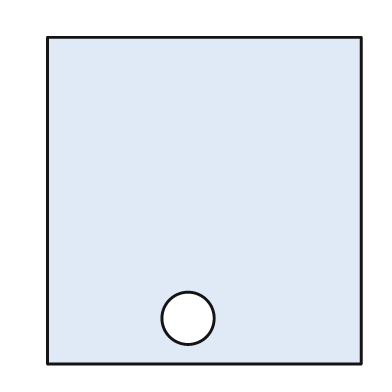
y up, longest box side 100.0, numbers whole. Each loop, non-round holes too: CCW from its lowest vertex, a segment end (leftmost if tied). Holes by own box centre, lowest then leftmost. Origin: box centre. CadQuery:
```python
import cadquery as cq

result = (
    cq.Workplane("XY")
    .moveTo(-48.0, -50.0)
    .lineTo(48.0, -50.0)
    .lineTo(48.0, 50.0)
    .lineTo(-48.0, 50.0)
    .close()
    .moveTo(-5.0, -36.0)
    .circle(8.0)
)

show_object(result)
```